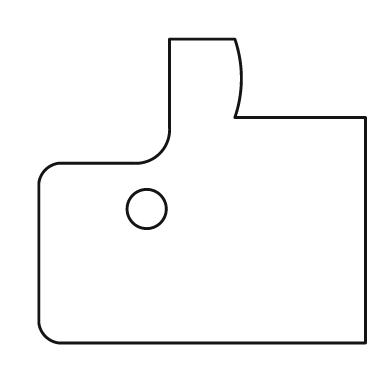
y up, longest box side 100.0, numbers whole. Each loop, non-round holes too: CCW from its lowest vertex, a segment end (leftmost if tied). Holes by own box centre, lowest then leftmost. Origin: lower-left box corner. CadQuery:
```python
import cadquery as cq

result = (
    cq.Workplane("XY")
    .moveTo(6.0, 0.0)
    .lineTo(100.0, 0.0)
    .lineTo(100.0, 69.0)
    .lineTo(60.0, 69.0)
    .threePointArc((62.0, 81.0), (60.0, 93.0))
    .lineTo(40.0, 93.0)
    .lineTo(40.0, 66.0)
    .threePointArc((37.0, 58.0), (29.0, 55.0))
    .lineTo(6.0, 55.0)
    .threePointArc((2.0, 53.0), (0.0, 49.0))
    .lineTo(0.0, 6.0)
    .threePointArc((2.0, 2.0), (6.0, 0.0))
    .close()
    .moveTo(33.0, 41.0)
    .circle(6.0)
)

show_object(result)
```